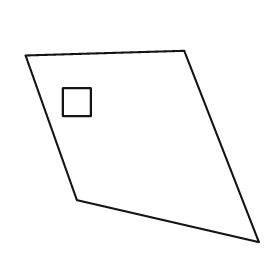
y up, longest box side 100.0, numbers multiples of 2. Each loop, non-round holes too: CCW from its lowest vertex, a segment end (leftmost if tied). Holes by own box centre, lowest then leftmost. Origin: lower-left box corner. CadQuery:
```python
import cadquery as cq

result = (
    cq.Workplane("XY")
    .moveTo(100.0, 0.0)
    .lineTo(68.0, 82.0)
    .lineTo(0.0, 80.0)
    .lineTo(22.0, 18.0)
    .close()
    .moveTo(16.0, 54.0)
    .lineTo(28.0, 54.0)
    .lineTo(28.0, 66.0)
    .lineTo(16.0, 66.0)
    .close()
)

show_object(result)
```